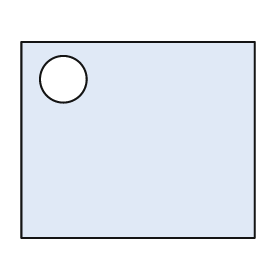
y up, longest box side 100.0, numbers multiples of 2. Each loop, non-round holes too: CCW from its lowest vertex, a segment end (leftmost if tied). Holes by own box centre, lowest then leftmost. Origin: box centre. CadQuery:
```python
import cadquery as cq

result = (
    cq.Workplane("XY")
    .moveTo(-50.0, -42.0)
    .lineTo(50.0, -42.0)
    .lineTo(50.0, 42.0)
    .lineTo(-50.0, 42.0)
    .close()
    .moveTo(-32.0, 26.0)
    .circle(10.0)
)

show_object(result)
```